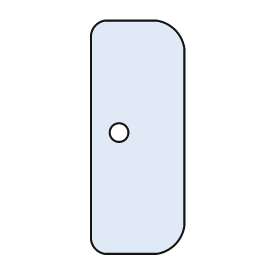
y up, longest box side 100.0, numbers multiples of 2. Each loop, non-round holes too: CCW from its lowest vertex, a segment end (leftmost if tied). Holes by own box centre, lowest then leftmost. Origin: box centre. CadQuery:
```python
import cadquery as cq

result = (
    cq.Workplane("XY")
    .moveTo(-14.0, -50.0)
    .lineTo(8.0, -50.0)
    .threePointArc((16.0, -46.0), (20.0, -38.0))
    .lineTo(20.0, 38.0)
    .threePointArc((16.0, 46.0), (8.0, 50.0))
    .lineTo(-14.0, 50.0)
    .threePointArc((-18.0, 48.0), (-20.0, 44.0))
    .lineTo(-20.0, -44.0)
    .threePointArc((-18.0, -48.0), (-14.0, -50.0))
    .close()
    .moveTo(-8.0, 2.0)
    .circle(4.0)
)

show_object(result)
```